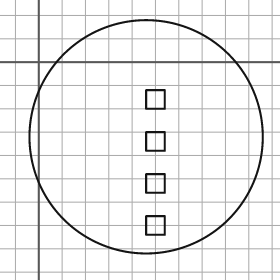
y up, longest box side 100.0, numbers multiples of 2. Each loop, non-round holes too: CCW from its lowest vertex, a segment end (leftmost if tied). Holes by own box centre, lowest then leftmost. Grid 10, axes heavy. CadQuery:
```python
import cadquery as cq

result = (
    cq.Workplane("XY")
    .moveTo(46.0, -32.0)
    .circle(50.0)
    .moveTo(46.0, -74.0)
    .lineTo(54.0, -74.0)
    .lineTo(54.0, -66.0)
    .lineTo(46.0, -66.0)
    .close()
    .moveTo(46.0, -56.0)
    .lineTo(54.0, -56.0)
    .lineTo(54.0, -48.0)
    .lineTo(46.0, -48.0)
    .close()
    .moveTo(46.0, -38.0)
    .lineTo(54.0, -38.0)
    .lineTo(54.0, -30.0)
    .lineTo(46.0, -30.0)
    .close()
    .moveTo(46.0, -20.0)
    .lineTo(54.0, -20.0)
    .lineTo(54.0, -12.0)
    .lineTo(46.0, -12.0)
    .close()
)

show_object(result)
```